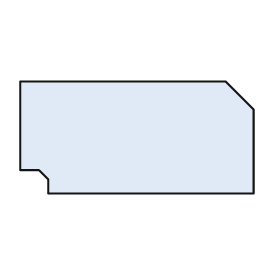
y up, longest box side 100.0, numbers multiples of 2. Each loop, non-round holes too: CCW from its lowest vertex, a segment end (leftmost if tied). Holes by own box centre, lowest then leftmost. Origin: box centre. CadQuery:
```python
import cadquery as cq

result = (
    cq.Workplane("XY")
    .moveTo(-38.0, -24.0)
    .lineTo(50.0, -24.0)
    .lineTo(50.0, 12.0)
    .lineTo(38.0, 24.0)
    .lineTo(-50.0, 24.0)
    .lineTo(-50.0, -14.0)
    .lineTo(-42.0, -14.0)
    .lineTo(-38.0, -18.0)
    .close()
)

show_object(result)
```